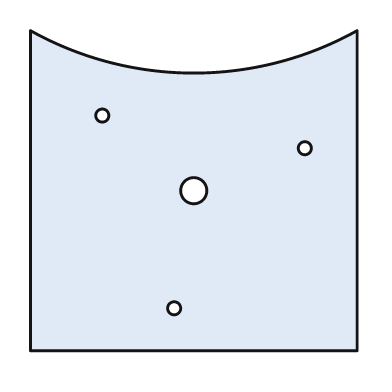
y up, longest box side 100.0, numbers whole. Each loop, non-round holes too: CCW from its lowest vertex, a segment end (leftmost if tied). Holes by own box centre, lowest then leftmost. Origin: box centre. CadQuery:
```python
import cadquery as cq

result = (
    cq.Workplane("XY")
    .moveTo(-50.0, -49.0)
    .lineTo(50.0, -49.0)
    .lineTo(50.0, 49.0)
    .threePointArc((0.0, 36.0), (-50.0, 49.0))
    .close()
    .moveTo(-6.0, -36.0)
    .circle(2.0)
    .moveTo(0.0, 0.0)
    .circle(4.0)
    .moveTo(34.0, 13.0)
    .circle(2.0)
    .moveTo(-28.0, 23.0)
    .circle(2.0)
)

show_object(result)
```